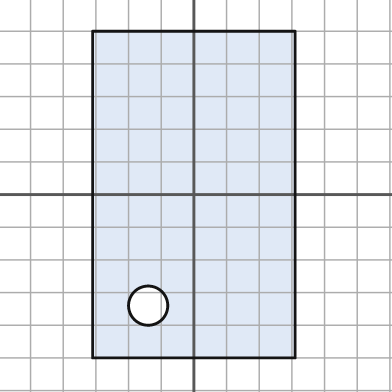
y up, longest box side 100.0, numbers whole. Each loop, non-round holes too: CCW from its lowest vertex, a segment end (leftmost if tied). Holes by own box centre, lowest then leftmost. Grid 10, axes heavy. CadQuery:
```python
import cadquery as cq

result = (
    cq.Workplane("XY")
    .moveTo(-31.0, -50.0)
    .lineTo(31.0, -50.0)
    .lineTo(31.0, 50.0)
    .lineTo(-31.0, 50.0)
    .close()
    .moveTo(-14.0, -34.0)
    .circle(6.0)
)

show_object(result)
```